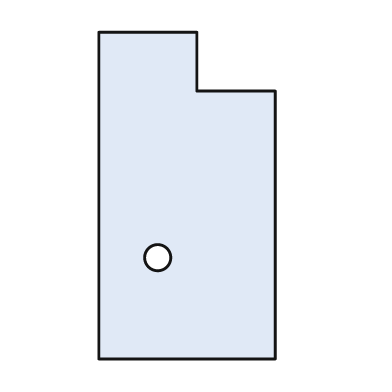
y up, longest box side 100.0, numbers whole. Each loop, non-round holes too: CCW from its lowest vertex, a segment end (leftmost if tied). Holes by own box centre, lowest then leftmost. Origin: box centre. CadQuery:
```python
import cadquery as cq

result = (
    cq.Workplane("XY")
    .moveTo(-27.0, -50.0)
    .lineTo(27.0, -50.0)
    .lineTo(27.0, 32.0)
    .lineTo(3.0, 32.0)
    .lineTo(3.0, 50.0)
    .lineTo(-27.0, 50.0)
    .close()
    .moveTo(-9.0, -19.0)
    .circle(4.0)
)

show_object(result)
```